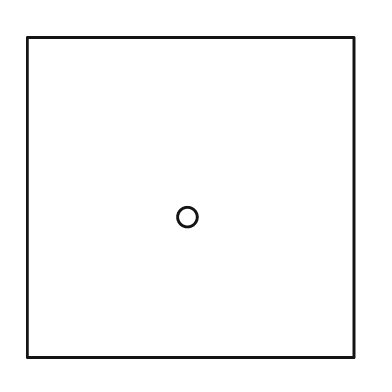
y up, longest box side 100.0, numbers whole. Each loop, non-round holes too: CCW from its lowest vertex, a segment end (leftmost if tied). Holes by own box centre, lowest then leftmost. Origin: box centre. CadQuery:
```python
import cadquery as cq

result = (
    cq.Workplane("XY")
    .moveTo(-50.0, -49.0)
    .lineTo(50.0, -49.0)
    .lineTo(50.0, 49.0)
    .lineTo(-50.0, 49.0)
    .close()
    .moveTo(-1.0, -6.0)
    .circle(3.0)
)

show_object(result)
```